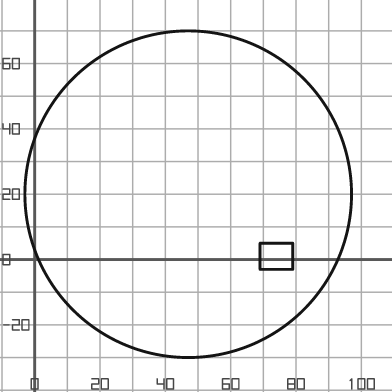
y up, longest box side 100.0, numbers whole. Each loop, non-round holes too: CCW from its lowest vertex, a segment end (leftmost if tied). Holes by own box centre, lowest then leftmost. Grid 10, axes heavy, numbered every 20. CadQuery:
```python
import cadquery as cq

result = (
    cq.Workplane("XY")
    .moveTo(47.0, 20.0)
    .circle(50.0)
    .moveTo(69.0, -3.0)
    .lineTo(79.0, -3.0)
    .lineTo(79.0, 5.0)
    .lineTo(69.0, 5.0)
    .close()
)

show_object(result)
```